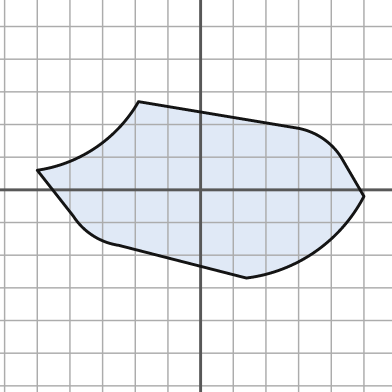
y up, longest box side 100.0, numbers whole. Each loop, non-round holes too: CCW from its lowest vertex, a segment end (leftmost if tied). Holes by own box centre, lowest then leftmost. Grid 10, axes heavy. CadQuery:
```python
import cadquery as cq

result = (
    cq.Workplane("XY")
    .moveTo(14.0, -27.0)
    .threePointArc((35.0, -19.0), (50.0, -2.0))
    .lineTo(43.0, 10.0)
    .threePointArc((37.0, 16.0), (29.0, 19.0))
    .lineTo(-19.0, 27.0)
    .threePointArc((-32.0, 13.0), (-50.0, 6.0))
    .lineTo(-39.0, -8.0)
    .threePointArc((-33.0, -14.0), (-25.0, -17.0))
    .close()
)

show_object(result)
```